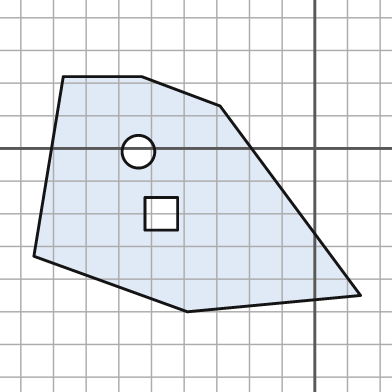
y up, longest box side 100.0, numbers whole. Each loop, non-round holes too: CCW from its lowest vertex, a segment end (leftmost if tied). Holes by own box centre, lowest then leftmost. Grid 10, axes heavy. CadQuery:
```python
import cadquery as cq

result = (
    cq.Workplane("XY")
    .moveTo(-39.0, -50.0)
    .lineTo(14.0, -45.0)
    .lineTo(-29.0, 13.0)
    .lineTo(-53.0, 22.0)
    .lineTo(-77.0, 22.0)
    .lineTo(-86.0, -33.0)
    .close()
    .moveTo(-52.0, -25.0)
    .lineTo(-42.0, -25.0)
    .lineTo(-42.0, -15.0)
    .lineTo(-52.0, -15.0)
    .close()
    .moveTo(-54.0, -1.0)
    .circle(5.0)
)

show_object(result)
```